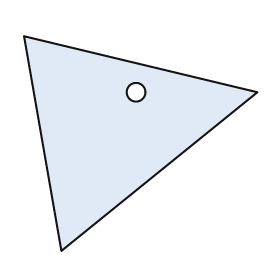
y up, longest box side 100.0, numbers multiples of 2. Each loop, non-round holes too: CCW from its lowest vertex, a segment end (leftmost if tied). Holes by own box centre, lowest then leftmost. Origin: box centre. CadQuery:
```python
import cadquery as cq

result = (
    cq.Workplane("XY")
    .moveTo(-34.0, -46.0)
    .lineTo(50.0, 22.0)
    .lineTo(-50.0, 46.0)
    .close()
    .moveTo(-2.0, 22.0)
    .circle(4.0)
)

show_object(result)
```